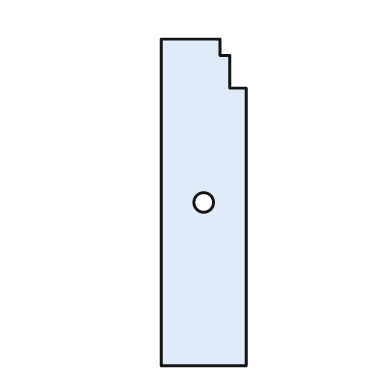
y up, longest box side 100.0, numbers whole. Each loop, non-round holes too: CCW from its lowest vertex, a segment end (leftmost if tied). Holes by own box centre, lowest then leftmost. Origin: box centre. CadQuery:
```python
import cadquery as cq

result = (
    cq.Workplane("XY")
    .moveTo(-13.0, -50.0)
    .lineTo(13.0, -50.0)
    .lineTo(13.0, 35.0)
    .lineTo(8.0, 35.0)
    .lineTo(8.0, 45.0)
    .lineTo(5.0, 45.0)
    .lineTo(5.0, 50.0)
    .lineTo(-13.0, 50.0)
    .close()
    .moveTo(0.0, 0.0)
    .circle(3.0)
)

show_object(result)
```